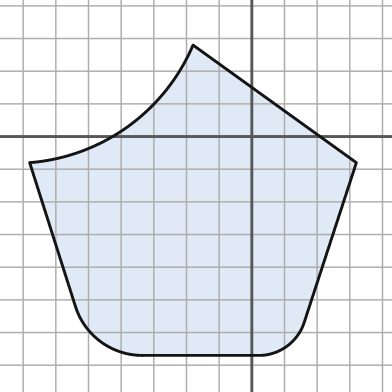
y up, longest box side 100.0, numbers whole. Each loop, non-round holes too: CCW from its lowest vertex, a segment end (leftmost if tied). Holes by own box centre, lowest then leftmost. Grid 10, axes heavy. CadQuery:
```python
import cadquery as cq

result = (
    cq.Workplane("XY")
    .moveTo(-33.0, -67.0)
    .lineTo(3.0, -67.0)
    .threePointArc((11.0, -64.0), (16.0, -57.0))
    .lineTo(32.0, -8.0)
    .lineTo(-18.0, 28.0)
    .threePointArc((-38.0, 3.0), (-68.0, -8.0))
    .lineTo(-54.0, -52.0)
    .threePointArc((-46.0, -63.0), (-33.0, -67.0))
    .close()
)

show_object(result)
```